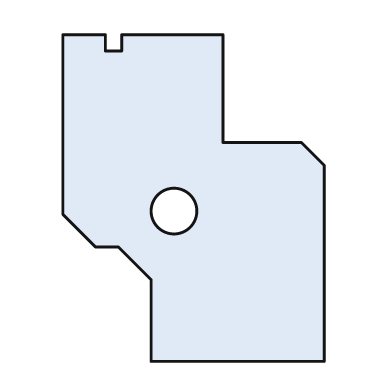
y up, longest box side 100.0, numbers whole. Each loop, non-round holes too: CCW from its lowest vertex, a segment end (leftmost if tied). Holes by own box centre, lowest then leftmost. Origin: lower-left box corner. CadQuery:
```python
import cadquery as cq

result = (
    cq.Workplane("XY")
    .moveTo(27.0, 0.0)
    .lineTo(80.0, 0.0)
    .lineTo(80.0, 60.0)
    .lineTo(73.0, 67.0)
    .lineTo(49.0, 67.0)
    .lineTo(49.0, 100.0)
    .lineTo(18.0, 100.0)
    .lineTo(18.0, 95.0)
    .lineTo(13.0, 95.0)
    .lineTo(13.0, 100.0)
    .lineTo(0.0, 100.0)
    .lineTo(0.0, 45.0)
    .lineTo(10.0, 35.0)
    .lineTo(17.0, 35.0)
    .lineTo(27.0, 25.0)
    .close()
    .moveTo(34.0, 46.0)
    .circle(7.0)
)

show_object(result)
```